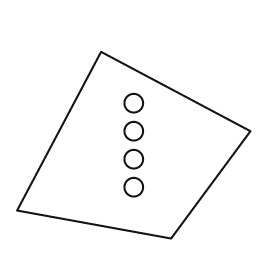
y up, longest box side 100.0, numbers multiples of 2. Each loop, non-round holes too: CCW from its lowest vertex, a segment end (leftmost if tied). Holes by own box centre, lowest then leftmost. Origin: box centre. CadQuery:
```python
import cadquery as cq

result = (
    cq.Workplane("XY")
    .moveTo(16.0, -40.0)
    .lineTo(50.0, 6.0)
    .lineTo(-14.0, 40.0)
    .lineTo(-50.0, -28.0)
    .close()
    .moveTo(0.0, -18.0)
    .circle(4.0)
    .moveTo(0.0, -6.0)
    .circle(4.0)
    .moveTo(0.0, 6.0)
    .circle(4.0)
    .moveTo(0.0, 18.0)
    .circle(4.0)
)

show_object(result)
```